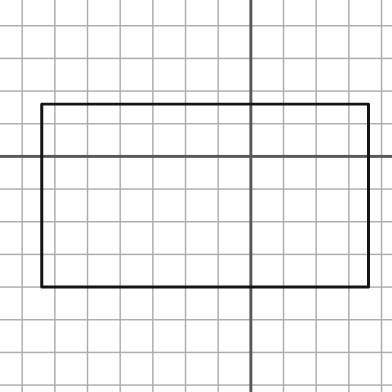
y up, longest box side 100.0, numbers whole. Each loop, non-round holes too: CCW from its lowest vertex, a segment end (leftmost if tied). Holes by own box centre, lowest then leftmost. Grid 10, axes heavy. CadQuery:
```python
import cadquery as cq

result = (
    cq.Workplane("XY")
    .moveTo(-64.0, -40.0)
    .lineTo(36.0, -40.0)
    .lineTo(36.0, 16.0)
    .lineTo(-64.0, 16.0)
    .close()
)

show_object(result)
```